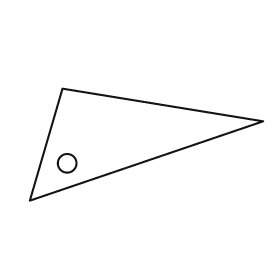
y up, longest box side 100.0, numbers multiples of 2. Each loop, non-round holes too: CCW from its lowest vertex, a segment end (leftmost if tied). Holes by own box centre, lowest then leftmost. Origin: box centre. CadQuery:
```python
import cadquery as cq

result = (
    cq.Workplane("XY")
    .moveTo(-50.0, -24.0)
    .lineTo(50.0, 10.0)
    .lineTo(-36.0, 24.0)
    .close()
    .moveTo(-34.0, -8.0)
    .circle(4.0)
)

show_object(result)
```